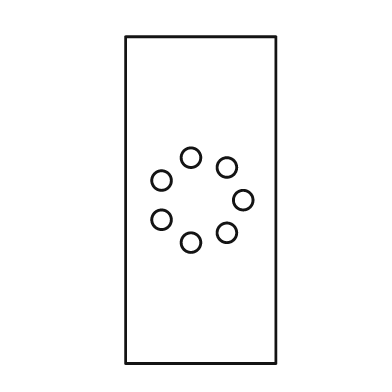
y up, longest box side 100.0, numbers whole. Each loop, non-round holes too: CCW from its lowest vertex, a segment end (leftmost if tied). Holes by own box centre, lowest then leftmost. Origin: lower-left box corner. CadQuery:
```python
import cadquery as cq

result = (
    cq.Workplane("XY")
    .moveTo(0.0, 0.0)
    .lineTo(46.0, 0.0)
    .lineTo(46.0, 100.0)
    .lineTo(0.0, 100.0)
    .close()
    .moveTo(20.0, 37.0)
    .circle(3.0)
    .moveTo(31.0, 40.0)
    .circle(3.0)
    .moveTo(11.0, 44.0)
    .circle(3.0)
    .moveTo(36.0, 50.0)
    .circle(3.0)
    .moveTo(11.0, 56.0)
    .circle(3.0)
    .moveTo(31.0, 60.0)
    .circle(3.0)
    .moveTo(20.0, 63.0)
    .circle(3.0)
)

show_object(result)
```